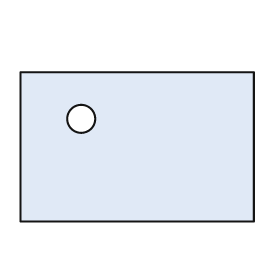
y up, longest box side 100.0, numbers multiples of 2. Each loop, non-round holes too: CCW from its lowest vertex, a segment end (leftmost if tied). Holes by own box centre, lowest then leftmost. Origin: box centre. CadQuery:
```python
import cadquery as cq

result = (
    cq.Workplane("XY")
    .moveTo(-50.0, -32.0)
    .lineTo(50.0, -32.0)
    .lineTo(50.0, 32.0)
    .lineTo(-50.0, 32.0)
    .close()
    .moveTo(-24.0, 12.0)
    .circle(6.0)
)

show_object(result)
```